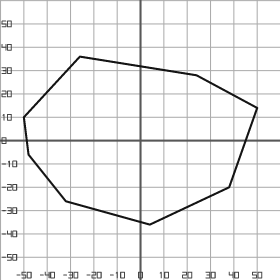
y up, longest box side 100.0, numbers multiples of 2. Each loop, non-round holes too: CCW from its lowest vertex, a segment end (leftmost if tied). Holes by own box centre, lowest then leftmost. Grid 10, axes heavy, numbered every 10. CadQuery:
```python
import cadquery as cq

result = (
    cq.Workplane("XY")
    .moveTo(4.0, -36.0)
    .lineTo(38.0, -20.0)
    .lineTo(50.0, 14.0)
    .lineTo(24.0, 28.0)
    .lineTo(-26.0, 36.0)
    .lineTo(-50.0, 10.0)
    .lineTo(-48.0, -6.0)
    .lineTo(-32.0, -26.0)
    .close()
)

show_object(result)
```